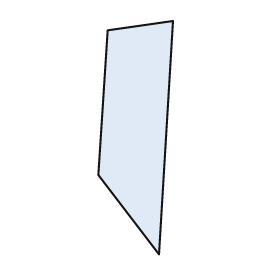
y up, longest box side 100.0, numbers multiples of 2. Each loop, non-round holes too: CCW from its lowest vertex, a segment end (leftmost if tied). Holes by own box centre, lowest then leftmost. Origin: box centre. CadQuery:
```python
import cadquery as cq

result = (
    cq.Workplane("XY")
    .moveTo(10.0, -50.0)
    .lineTo(16.0, 50.0)
    .lineTo(-12.0, 46.0)
    .lineTo(-16.0, -16.0)
    .close()
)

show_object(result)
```